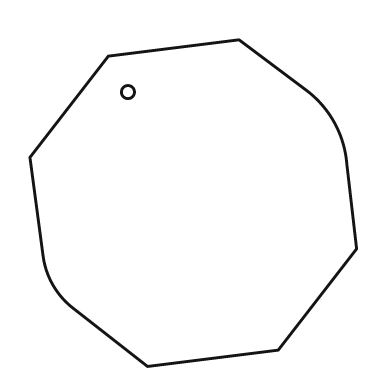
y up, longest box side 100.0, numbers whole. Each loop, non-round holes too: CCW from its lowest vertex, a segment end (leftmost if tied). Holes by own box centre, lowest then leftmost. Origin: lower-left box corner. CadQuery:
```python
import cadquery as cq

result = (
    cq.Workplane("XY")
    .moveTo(36.0, 0.0)
    .lineTo(76.0, 5.0)
    .lineTo(100.0, 36.0)
    .lineTo(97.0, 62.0)
    .threePointArc((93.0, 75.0), (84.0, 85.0))
    .lineTo(64.0, 100.0)
    .lineTo(24.0, 95.0)
    .lineTo(0.0, 64.0)
    .lineTo(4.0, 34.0)
    .threePointArc((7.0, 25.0), (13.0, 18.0))
    .close()
    .moveTo(30.0, 84.0)
    .circle(2.0)
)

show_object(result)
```